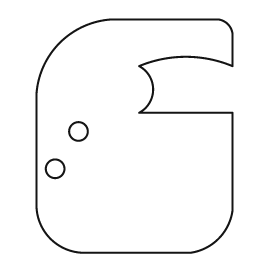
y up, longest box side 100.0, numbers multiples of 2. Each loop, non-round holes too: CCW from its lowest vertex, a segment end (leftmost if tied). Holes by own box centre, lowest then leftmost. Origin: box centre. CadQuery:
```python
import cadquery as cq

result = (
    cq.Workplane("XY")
    .moveTo(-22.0, -50.0)
    .lineTo(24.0, -50.0)
    .threePointArc((36.0, -44.0), (42.0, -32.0))
    .lineTo(42.0, 10.0)
    .lineTo(2.0, 10.0)
    .threePointArc((8.0, 20.0), (2.0, 30.0))
    .threePointArc((22.0, 34.0), (42.0, 30.0))
    .lineTo(42.0, 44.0)
    .threePointArc((40.0, 48.0), (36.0, 50.0))
    .lineTo(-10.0, 50.0)
    .threePointArc((-32.0, 40.0), (-42.0, 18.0))
    .lineTo(-42.0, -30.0)
    .threePointArc((-36.0, -44.0), (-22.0, -50.0))
    .close()
    .moveTo(-34.0, -14.0)
    .circle(4.0)
    .moveTo(-24.0, 2.0)
    .circle(4.0)
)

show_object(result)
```